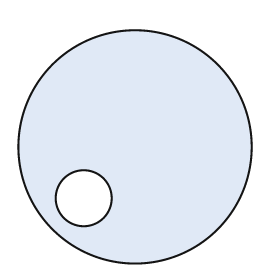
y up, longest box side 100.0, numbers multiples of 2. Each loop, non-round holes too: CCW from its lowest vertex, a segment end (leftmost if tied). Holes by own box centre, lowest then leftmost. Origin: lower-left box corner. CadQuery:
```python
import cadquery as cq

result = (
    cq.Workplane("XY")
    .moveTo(50.0, 50.0)
    .circle(50.0)
    .moveTo(28.0, 28.0)
    .circle(12.0)
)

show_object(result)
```